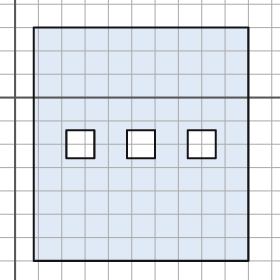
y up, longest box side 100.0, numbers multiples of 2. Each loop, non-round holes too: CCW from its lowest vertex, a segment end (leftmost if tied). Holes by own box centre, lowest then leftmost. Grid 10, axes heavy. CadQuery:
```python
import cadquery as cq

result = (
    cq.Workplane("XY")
    .moveTo(8.0, -70.0)
    .lineTo(100.0, -70.0)
    .lineTo(100.0, 30.0)
    .lineTo(8.0, 30.0)
    .close()
    .moveTo(22.0, -26.0)
    .lineTo(34.0, -26.0)
    .lineTo(34.0, -14.0)
    .lineTo(22.0, -14.0)
    .close()
    .moveTo(48.0, -26.0)
    .lineTo(60.0, -26.0)
    .lineTo(60.0, -14.0)
    .lineTo(48.0, -14.0)
    .close()
    .moveTo(74.0, -26.0)
    .lineTo(86.0, -26.0)
    .lineTo(86.0, -14.0)
    .lineTo(74.0, -14.0)
    .close()
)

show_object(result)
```